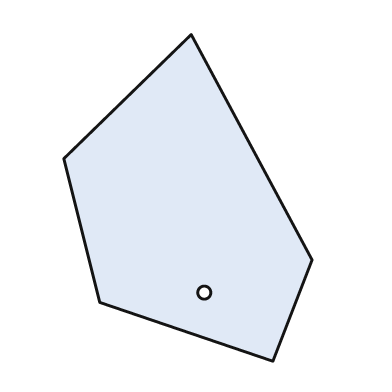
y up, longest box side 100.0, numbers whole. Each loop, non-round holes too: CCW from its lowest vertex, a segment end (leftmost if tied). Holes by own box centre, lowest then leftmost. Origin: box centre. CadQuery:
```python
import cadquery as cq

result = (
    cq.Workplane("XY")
    .moveTo(26.0, -50.0)
    .lineTo(38.0, -19.0)
    .lineTo(1.0, 50.0)
    .lineTo(-38.0, 12.0)
    .lineTo(-27.0, -32.0)
    .close()
    .moveTo(5.0, -29.0)
    .circle(2.0)
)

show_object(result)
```